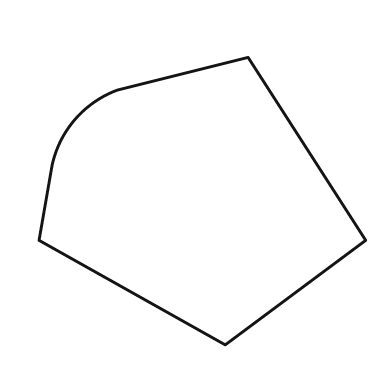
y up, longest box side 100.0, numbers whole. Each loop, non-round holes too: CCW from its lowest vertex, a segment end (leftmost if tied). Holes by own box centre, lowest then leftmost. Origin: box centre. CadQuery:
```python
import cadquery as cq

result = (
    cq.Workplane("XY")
    .moveTo(7.0, -44.0)
    .lineTo(50.0, -12.0)
    .lineTo(14.0, 44.0)
    .lineTo(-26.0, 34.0)
    .threePointArc((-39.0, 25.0), (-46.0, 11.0))
    .lineTo(-50.0, -12.0)
    .close()
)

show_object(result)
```